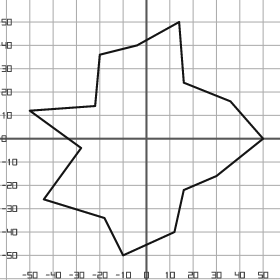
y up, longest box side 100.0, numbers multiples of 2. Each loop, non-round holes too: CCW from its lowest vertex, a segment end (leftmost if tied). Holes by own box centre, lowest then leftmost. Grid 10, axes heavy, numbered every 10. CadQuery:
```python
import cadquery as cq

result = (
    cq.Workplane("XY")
    .moveTo(-10.0, -50.0)
    .lineTo(12.0, -40.0)
    .lineTo(16.0, -22.0)
    .lineTo(30.0, -16.0)
    .lineTo(50.0, 0.0)
    .lineTo(36.0, 16.0)
    .lineTo(16.0, 24.0)
    .lineTo(14.0, 50.0)
    .lineTo(-4.0, 40.0)
    .lineTo(-20.0, 36.0)
    .lineTo(-22.0, 14.0)
    .lineTo(-50.0, 12.0)
    .lineTo(-28.0, -4.0)
    .lineTo(-44.0, -26.0)
    .lineTo(-18.0, -34.0)
    .close()
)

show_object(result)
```